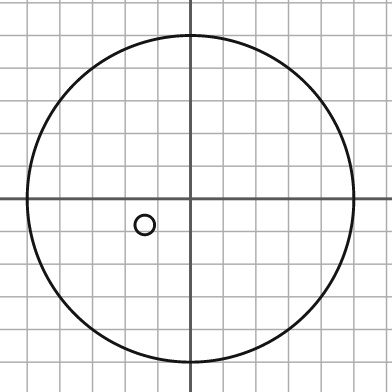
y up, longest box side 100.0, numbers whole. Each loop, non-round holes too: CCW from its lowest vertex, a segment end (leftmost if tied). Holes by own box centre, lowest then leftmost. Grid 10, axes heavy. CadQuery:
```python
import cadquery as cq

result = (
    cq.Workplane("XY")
    .moveTo(0.0, 0.0)
    .circle(50.0)
    .moveTo(-14.0, -8.0)
    .circle(3.0)
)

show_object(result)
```